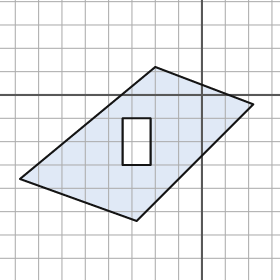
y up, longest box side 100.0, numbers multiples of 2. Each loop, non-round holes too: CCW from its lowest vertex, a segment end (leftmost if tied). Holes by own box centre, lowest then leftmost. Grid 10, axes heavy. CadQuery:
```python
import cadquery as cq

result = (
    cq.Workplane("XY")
    .moveTo(-28.0, -54.0)
    .lineTo(22.0, -4.0)
    .lineTo(-20.0, 12.0)
    .lineTo(-78.0, -36.0)
    .close()
    .moveTo(-34.0, -30.0)
    .lineTo(-22.0, -30.0)
    .lineTo(-22.0, -10.0)
    .lineTo(-34.0, -10.0)
    .close()
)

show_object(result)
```